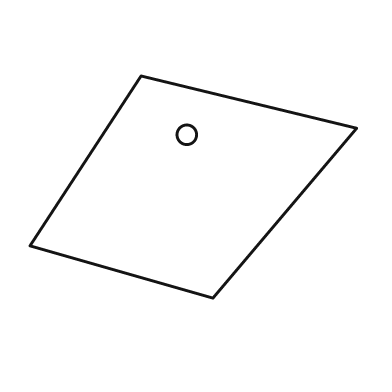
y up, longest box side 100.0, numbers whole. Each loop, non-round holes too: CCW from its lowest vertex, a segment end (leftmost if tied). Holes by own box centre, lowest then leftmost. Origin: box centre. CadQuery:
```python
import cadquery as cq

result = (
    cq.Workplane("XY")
    .moveTo(6.0, -34.0)
    .lineTo(50.0, 18.0)
    .lineTo(-16.0, 34.0)
    .lineTo(-50.0, -18.0)
    .close()
    .moveTo(-2.0, 16.0)
    .circle(3.0)
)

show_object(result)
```